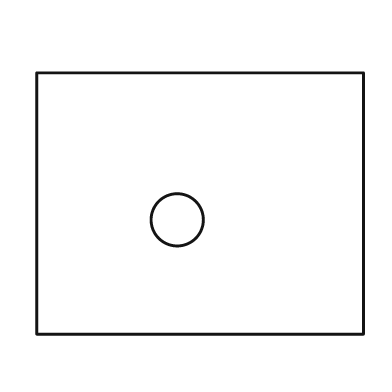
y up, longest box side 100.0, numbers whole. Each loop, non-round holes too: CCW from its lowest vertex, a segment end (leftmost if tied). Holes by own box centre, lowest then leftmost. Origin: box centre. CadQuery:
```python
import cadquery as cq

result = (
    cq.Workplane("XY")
    .moveTo(-50.0, -40.0)
    .lineTo(50.0, -40.0)
    .lineTo(50.0, 40.0)
    .lineTo(-50.0, 40.0)
    .close()
    .moveTo(-7.0, -5.0)
    .circle(8.0)
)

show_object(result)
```